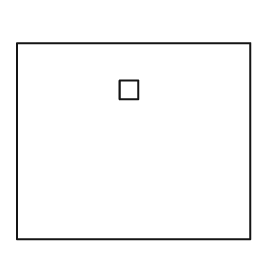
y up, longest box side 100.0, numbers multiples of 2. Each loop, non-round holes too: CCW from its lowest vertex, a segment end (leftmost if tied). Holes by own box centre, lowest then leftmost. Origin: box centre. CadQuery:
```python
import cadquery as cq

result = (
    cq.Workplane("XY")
    .moveTo(-50.0, -42.0)
    .lineTo(50.0, -42.0)
    .lineTo(50.0, 42.0)
    .lineTo(-50.0, 42.0)
    .close()
    .moveTo(-6.0, 18.0)
    .lineTo(2.0, 18.0)
    .lineTo(2.0, 26.0)
    .lineTo(-6.0, 26.0)
    .close()
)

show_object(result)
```